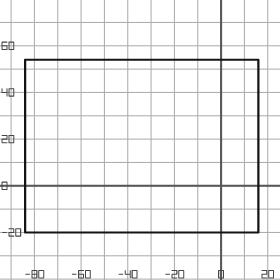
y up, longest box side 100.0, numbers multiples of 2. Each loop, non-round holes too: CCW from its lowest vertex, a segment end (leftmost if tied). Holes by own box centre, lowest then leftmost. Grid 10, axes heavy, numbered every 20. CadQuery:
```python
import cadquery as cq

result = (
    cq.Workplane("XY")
    .moveTo(-84.0, -20.0)
    .lineTo(16.0, -20.0)
    .lineTo(16.0, 54.0)
    .lineTo(-84.0, 54.0)
    .close()
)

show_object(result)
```